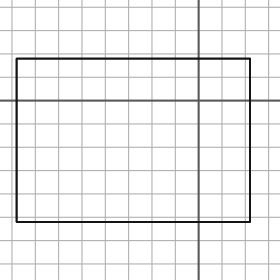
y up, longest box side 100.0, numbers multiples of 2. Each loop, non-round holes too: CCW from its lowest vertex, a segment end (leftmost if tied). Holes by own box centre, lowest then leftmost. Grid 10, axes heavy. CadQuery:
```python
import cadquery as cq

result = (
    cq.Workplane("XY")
    .moveTo(-78.0, -52.0)
    .lineTo(22.0, -52.0)
    .lineTo(22.0, 18.0)
    .lineTo(-78.0, 18.0)
    .close()
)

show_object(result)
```